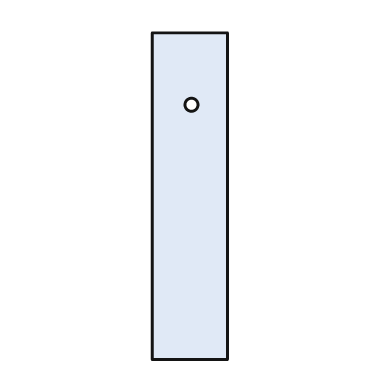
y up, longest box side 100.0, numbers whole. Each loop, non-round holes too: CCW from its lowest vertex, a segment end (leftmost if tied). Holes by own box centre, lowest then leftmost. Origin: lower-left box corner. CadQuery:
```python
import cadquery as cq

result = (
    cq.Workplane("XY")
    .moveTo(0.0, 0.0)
    .lineTo(23.0, 0.0)
    .lineTo(23.0, 100.0)
    .lineTo(0.0, 100.0)
    .close()
    .moveTo(12.0, 78.0)
    .circle(2.0)
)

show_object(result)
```